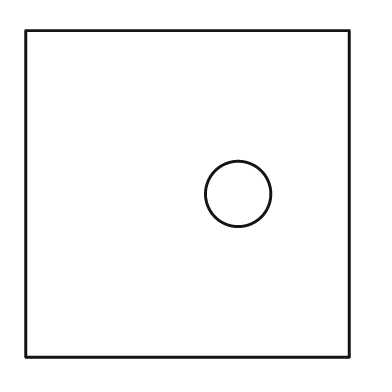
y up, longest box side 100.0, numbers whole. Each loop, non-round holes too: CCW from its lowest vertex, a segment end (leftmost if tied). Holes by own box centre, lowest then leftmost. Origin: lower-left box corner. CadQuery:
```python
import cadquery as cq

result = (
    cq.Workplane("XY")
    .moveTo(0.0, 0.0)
    .lineTo(99.0, 0.0)
    .lineTo(99.0, 100.0)
    .lineTo(0.0, 100.0)
    .close()
    .moveTo(65.0, 50.0)
    .circle(10.0)
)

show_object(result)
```